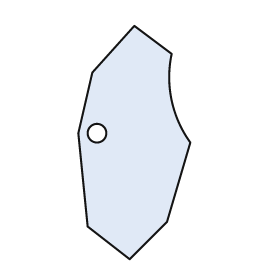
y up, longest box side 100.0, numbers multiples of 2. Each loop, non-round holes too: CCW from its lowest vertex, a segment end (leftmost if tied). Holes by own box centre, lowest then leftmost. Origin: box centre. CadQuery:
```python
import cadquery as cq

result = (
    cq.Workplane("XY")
    .moveTo(-2.0, -50.0)
    .lineTo(14.0, -34.0)
    .lineTo(24.0, 0.0)
    .threePointArc((16.0, 18.0), (16.0, 38.0))
    .lineTo(0.0, 50.0)
    .lineTo(-18.0, 30.0)
    .lineTo(-24.0, 4.0)
    .lineTo(-20.0, -36.0)
    .close()
    .moveTo(-16.0, 4.0)
    .circle(4.0)
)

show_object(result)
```